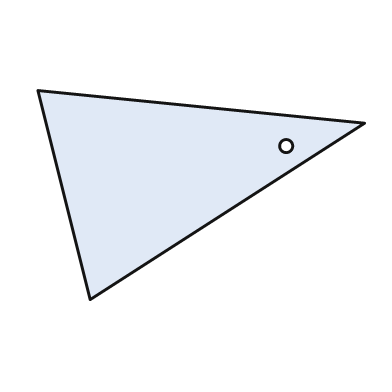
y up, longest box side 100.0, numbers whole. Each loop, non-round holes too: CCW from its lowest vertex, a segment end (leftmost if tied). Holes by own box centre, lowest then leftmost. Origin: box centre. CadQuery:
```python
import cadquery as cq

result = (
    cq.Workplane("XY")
    .moveTo(-34.0, -32.0)
    .lineTo(50.0, 22.0)
    .lineTo(-50.0, 32.0)
    .close()
    .moveTo(26.0, 15.0)
    .circle(2.0)
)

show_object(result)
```